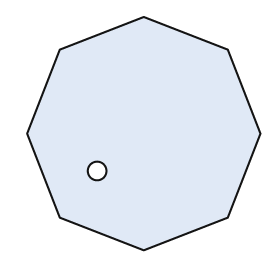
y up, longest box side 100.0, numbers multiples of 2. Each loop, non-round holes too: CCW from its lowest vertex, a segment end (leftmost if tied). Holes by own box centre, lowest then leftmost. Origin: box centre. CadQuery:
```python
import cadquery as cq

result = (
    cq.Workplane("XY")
    .moveTo(0.0, -50.0)
    .lineTo(36.0, -36.0)
    .lineTo(50.0, 0.0)
    .lineTo(36.0, 36.0)
    .lineTo(0.0, 50.0)
    .lineTo(-36.0, 36.0)
    .lineTo(-50.0, 0.0)
    .lineTo(-36.0, -36.0)
    .close()
    .moveTo(-20.0, -16.0)
    .circle(4.0)
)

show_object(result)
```